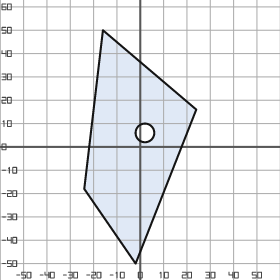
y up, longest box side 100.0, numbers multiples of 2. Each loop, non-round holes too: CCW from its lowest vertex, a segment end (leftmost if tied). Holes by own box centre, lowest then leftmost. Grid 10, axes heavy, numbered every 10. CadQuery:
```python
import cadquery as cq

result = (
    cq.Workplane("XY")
    .moveTo(-2.0, -50.0)
    .lineTo(24.0, 16.0)
    .lineTo(-16.0, 50.0)
    .lineTo(-24.0, -18.0)
    .close()
    .moveTo(2.0, 6.0)
    .circle(4.0)
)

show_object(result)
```